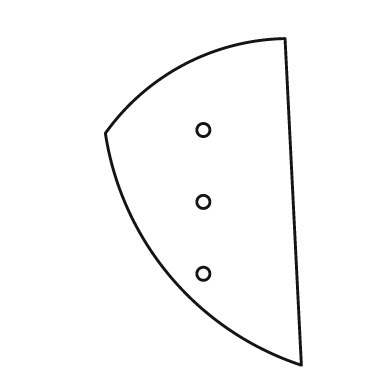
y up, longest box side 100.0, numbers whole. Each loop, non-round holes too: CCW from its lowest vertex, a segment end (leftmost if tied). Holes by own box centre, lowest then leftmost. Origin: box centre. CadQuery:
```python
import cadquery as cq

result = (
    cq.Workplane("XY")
    .moveTo(30.0, -50.0)
    .lineTo(25.0, 50.0)
    .threePointArc((-6.0, 42.0), (-30.0, 21.0))
    .threePointArc((-10.0, -23.0), (30.0, -50.0))
    .close()
    .moveTo(0.0, -22.0)
    .circle(2.0)
    .moveTo(0.0, 0.0)
    .circle(2.0)
    .moveTo(0.0, 22.0)
    .circle(2.0)
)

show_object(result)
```